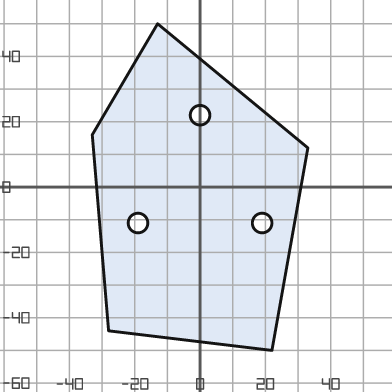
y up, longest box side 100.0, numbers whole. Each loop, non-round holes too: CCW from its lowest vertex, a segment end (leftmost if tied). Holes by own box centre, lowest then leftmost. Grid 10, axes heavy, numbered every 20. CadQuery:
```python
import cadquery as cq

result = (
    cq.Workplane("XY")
    .moveTo(22.0, -50.0)
    .lineTo(33.0, 12.0)
    .lineTo(-13.0, 50.0)
    .lineTo(-33.0, 16.0)
    .lineTo(-28.0, -44.0)
    .close()
    .moveTo(-19.0, -11.0)
    .circle(3.0)
    .moveTo(19.0, -11.0)
    .circle(3.0)
    .moveTo(0.0, 22.0)
    .circle(3.0)
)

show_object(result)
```